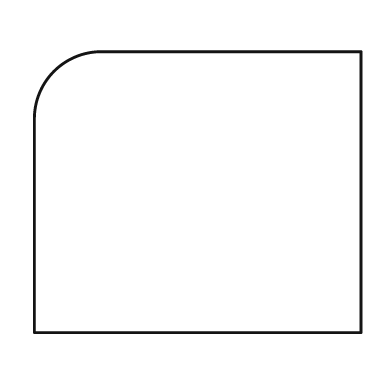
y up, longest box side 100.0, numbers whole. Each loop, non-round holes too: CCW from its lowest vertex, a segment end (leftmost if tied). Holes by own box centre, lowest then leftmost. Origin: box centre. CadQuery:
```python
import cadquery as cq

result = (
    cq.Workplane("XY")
    .moveTo(-50.0, -43.0)
    .lineTo(50.0, -43.0)
    .lineTo(50.0, 43.0)
    .lineTo(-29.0, 43.0)
    .threePointArc((-44.0, 37.0), (-50.0, 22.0))
    .close()
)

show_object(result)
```